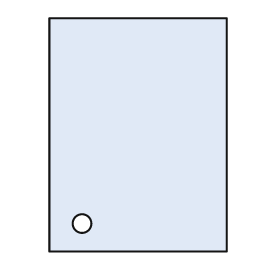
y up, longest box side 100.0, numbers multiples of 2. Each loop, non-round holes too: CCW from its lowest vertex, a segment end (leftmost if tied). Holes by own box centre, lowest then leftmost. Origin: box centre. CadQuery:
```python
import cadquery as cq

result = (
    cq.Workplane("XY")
    .moveTo(-38.0, -50.0)
    .lineTo(38.0, -50.0)
    .lineTo(38.0, 50.0)
    .lineTo(-38.0, 50.0)
    .close()
    .moveTo(-24.0, -38.0)
    .circle(4.0)
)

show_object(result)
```